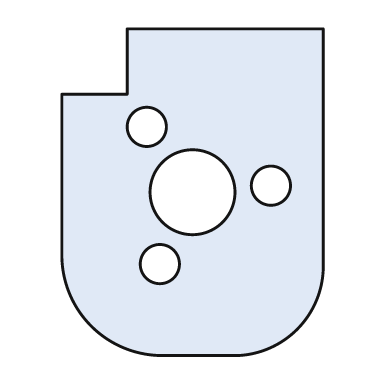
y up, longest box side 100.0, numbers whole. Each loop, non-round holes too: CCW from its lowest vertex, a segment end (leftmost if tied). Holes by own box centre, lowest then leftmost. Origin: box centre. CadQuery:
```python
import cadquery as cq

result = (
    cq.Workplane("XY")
    .moveTo(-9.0, -50.0)
    .lineTo(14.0, -50.0)
    .threePointArc((32.0, -42.0), (40.0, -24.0))
    .lineTo(40.0, 50.0)
    .lineTo(-20.0, 50.0)
    .lineTo(-20.0, 30.0)
    .lineTo(-40.0, 30.0)
    .lineTo(-40.0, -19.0)
    .threePointArc((-31.0, -41.0), (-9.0, -50.0))
    .close()
    .moveTo(-10.0, -22.0)
    .circle(6.0)
    .moveTo(0.0, 0.0)
    .circle(13.0)
    .moveTo(24.0, 2.0)
    .circle(6.0)
    .moveTo(-14.0, 20.0)
    .circle(6.0)
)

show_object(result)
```